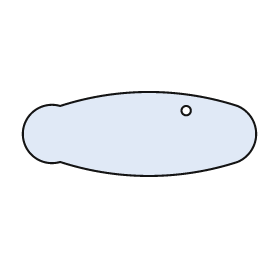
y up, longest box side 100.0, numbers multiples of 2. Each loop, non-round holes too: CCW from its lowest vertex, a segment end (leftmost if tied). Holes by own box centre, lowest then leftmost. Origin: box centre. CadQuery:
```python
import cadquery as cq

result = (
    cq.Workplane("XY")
    .moveTo(-34.0, -12.0)
    .threePointArc((4.0, -18.0), (42.0, -12.0))
    .threePointArc((50.0, 0.0), (42.0, 12.0))
    .threePointArc((4.0, 18.0), (-34.0, 12.0))
    .threePointArc((-50.0, 0.0), (-34.0, -12.0))
    .close()
    .moveTo(20.0, 10.0)
    .circle(2.0)
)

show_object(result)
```